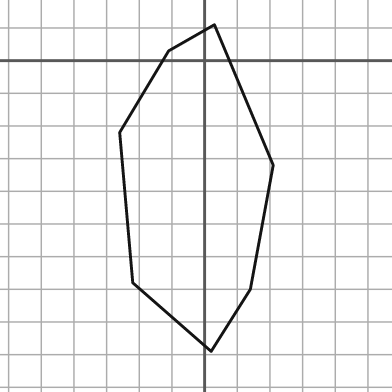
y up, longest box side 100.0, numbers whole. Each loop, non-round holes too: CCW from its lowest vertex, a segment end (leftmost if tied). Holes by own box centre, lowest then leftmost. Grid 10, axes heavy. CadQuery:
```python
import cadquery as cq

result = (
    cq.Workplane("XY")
    .moveTo(2.0, -89.0)
    .lineTo(14.0, -70.0)
    .lineTo(21.0, -32.0)
    .lineTo(3.0, 11.0)
    .lineTo(-11.0, 3.0)
    .lineTo(-26.0, -22.0)
    .lineTo(-22.0, -68.0)
    .close()
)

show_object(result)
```